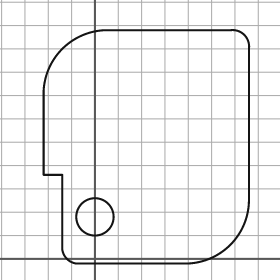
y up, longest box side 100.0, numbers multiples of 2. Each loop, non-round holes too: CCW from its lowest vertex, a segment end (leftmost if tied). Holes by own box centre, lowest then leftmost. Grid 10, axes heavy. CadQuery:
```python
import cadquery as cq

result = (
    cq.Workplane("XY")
    .moveTo(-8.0, -2.0)
    .lineTo(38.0, -2.0)
    .threePointArc((58.0, 6.0), (66.0, 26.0))
    .lineTo(66.0, 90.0)
    .threePointArc((64.0, 96.0), (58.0, 98.0))
    .lineTo(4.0, 98.0)
    .threePointArc((-14.0, 90.0), (-22.0, 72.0))
    .lineTo(-22.0, 36.0)
    .lineTo(-14.0, 36.0)
    .lineTo(-14.0, 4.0)
    .threePointArc((-12.0, 0.0), (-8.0, -2.0))
    .close()
    .moveTo(0.0, 18.0)
    .circle(8.0)
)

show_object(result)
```